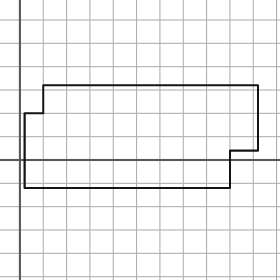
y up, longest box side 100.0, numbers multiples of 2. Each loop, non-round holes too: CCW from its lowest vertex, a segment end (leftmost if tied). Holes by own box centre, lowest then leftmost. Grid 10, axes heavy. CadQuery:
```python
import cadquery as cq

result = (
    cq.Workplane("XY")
    .moveTo(2.0, -12.0)
    .lineTo(90.0, -12.0)
    .lineTo(90.0, 4.0)
    .lineTo(102.0, 4.0)
    .lineTo(102.0, 32.0)
    .lineTo(10.0, 32.0)
    .lineTo(10.0, 20.0)
    .lineTo(2.0, 20.0)
    .close()
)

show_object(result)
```